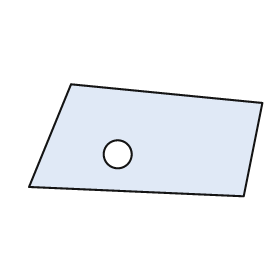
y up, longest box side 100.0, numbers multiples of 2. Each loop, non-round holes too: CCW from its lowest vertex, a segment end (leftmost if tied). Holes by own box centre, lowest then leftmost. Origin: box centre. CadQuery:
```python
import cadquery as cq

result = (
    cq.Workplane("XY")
    .moveTo(42.0, -24.0)
    .lineTo(50.0, 16.0)
    .lineTo(-32.0, 24.0)
    .lineTo(-50.0, -20.0)
    .close()
    .moveTo(-12.0, -6.0)
    .circle(6.0)
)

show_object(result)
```